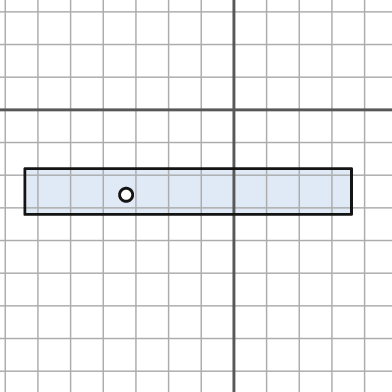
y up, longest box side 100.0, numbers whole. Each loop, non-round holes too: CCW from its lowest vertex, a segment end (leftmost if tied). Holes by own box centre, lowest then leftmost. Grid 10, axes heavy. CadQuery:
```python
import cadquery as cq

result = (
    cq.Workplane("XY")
    .moveTo(-64.0, -32.0)
    .lineTo(36.0, -32.0)
    .lineTo(36.0, -18.0)
    .lineTo(-64.0, -18.0)
    .close()
    .moveTo(-33.0, -26.0)
    .circle(2.0)
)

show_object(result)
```